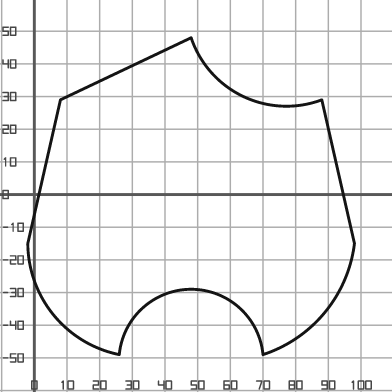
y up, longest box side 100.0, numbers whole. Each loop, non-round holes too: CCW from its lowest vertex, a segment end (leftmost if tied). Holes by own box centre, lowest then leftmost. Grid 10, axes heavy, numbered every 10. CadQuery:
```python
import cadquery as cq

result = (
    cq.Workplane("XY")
    .moveTo(26.0, -49.0)
    .threePointArc((48.0, -29.0), (70.0, -49.0))
    .threePointArc((89.0, -36.0), (98.0, -15.0))
    .lineTo(88.0, 29.0)
    .threePointArc((64.0, 30.0), (48.0, 48.0))
    .lineTo(8.0, 29.0)
    .lineTo(-2.0, -15.0)
    .threePointArc((6.0, -37.0), (26.0, -49.0))
    .close()
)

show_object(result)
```